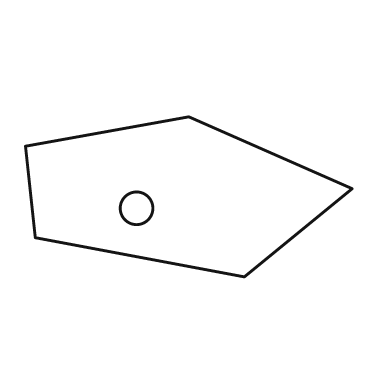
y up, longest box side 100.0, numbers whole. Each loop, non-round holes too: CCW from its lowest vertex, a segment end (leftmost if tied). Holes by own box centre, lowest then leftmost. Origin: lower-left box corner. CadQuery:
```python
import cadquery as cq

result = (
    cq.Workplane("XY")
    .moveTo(67.0, 0.0)
    .lineTo(100.0, 27.0)
    .lineTo(50.0, 49.0)
    .lineTo(0.0, 40.0)
    .lineTo(3.0, 12.0)
    .close()
    .moveTo(34.0, 21.0)
    .circle(5.0)
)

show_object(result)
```